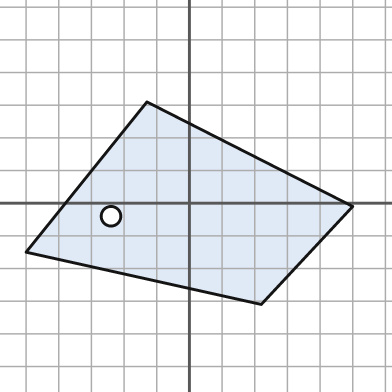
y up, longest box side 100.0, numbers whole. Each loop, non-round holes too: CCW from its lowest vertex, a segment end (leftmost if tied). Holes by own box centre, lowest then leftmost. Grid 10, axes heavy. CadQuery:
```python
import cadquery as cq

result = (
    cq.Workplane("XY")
    .moveTo(22.0, -31.0)
    .lineTo(50.0, -1.0)
    .lineTo(-13.0, 31.0)
    .lineTo(-50.0, -15.0)
    .close()
    .moveTo(-24.0, -4.0)
    .circle(3.0)
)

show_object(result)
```